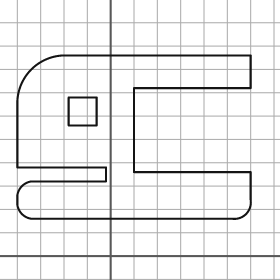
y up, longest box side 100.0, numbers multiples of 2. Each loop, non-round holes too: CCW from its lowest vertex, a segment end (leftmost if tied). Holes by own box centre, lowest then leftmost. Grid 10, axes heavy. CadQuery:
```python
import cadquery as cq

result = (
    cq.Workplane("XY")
    .moveTo(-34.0, 16.0)
    .lineTo(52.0, 16.0)
    .threePointArc((58.0, 18.0), (60.0, 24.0))
    .lineTo(60.0, 36.0)
    .lineTo(10.0, 36.0)
    .lineTo(10.0, 72.0)
    .lineTo(60.0, 72.0)
    .lineTo(60.0, 86.0)
    .lineTo(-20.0, 86.0)
    .threePointArc((-34.0, 80.0), (-40.0, 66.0))
    .lineTo(-40.0, 38.0)
    .lineTo(-2.0, 38.0)
    .lineTo(-2.0, 32.0)
    .lineTo(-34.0, 32.0)
    .threePointArc((-38.0, 30.0), (-40.0, 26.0))
    .lineTo(-40.0, 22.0)
    .threePointArc((-38.0, 18.0), (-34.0, 16.0))
    .close()
    .moveTo(-18.0, 56.0)
    .lineTo(-6.0, 56.0)
    .lineTo(-6.0, 68.0)
    .lineTo(-18.0, 68.0)
    .close()
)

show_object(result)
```